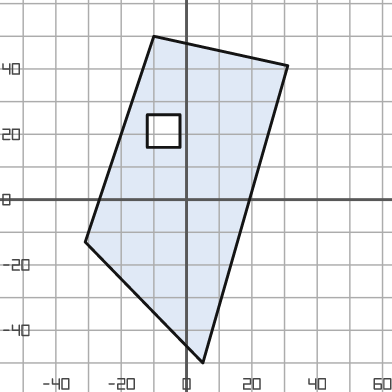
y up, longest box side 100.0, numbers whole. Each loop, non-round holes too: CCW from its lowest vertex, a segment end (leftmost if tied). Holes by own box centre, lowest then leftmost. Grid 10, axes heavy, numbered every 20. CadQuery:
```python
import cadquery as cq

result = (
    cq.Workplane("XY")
    .moveTo(5.0, -50.0)
    .lineTo(31.0, 41.0)
    .lineTo(-10.0, 50.0)
    .lineTo(-31.0, -13.0)
    .close()
    .moveTo(-12.0, 16.0)
    .lineTo(-2.0, 16.0)
    .lineTo(-2.0, 26.0)
    .lineTo(-12.0, 26.0)
    .close()
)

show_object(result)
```